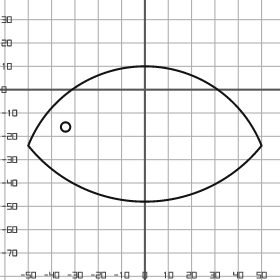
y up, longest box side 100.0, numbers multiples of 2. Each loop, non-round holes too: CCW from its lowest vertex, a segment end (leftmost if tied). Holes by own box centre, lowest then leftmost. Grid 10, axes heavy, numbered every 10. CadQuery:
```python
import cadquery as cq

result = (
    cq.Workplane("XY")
    .moveTo(-50.0, -24.0)
    .threePointArc((0.0, -48.0), (50.0, -24.0))
    .threePointArc((0.0, 10.0), (-50.0, -24.0))
    .close()
    .moveTo(-34.0, -16.0)
    .circle(2.0)
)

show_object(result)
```